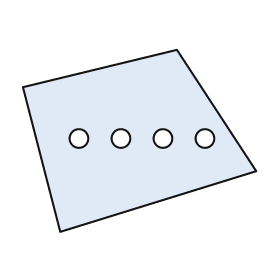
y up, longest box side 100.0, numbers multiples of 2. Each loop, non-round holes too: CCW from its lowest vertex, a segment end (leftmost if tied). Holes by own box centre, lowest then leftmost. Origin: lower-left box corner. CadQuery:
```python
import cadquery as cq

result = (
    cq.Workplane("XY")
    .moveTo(16.0, 0.0)
    .lineTo(100.0, 26.0)
    .lineTo(66.0, 78.0)
    .lineTo(0.0, 62.0)
    .close()
    .moveTo(24.0, 40.0)
    .circle(4.0)
    .moveTo(42.0, 40.0)
    .circle(4.0)
    .moveTo(60.0, 40.0)
    .circle(4.0)
    .moveTo(78.0, 40.0)
    .circle(4.0)
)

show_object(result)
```